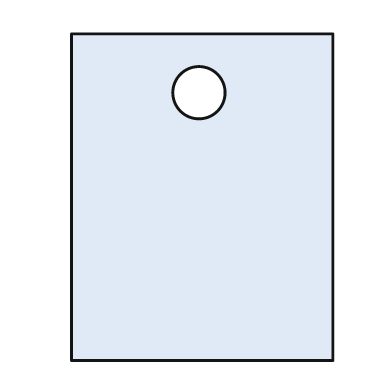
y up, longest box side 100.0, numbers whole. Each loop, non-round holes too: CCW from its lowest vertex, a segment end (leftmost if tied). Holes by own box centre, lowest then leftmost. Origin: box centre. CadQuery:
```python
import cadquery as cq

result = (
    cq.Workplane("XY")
    .moveTo(-40.0, -50.0)
    .lineTo(40.0, -50.0)
    .lineTo(40.0, 50.0)
    .lineTo(-40.0, 50.0)
    .close()
    .moveTo(-1.0, 32.0)
    .circle(8.0)
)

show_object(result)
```